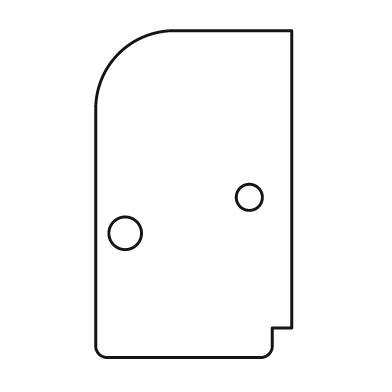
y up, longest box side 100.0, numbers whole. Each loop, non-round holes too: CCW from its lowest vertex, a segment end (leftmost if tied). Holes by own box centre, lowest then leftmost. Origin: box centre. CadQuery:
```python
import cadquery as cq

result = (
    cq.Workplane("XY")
    .moveTo(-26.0, -50.0)
    .lineTo(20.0, -50.0)
    .threePointArc((23.0, -49.0), (24.0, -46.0))
    .lineTo(24.0, -41.0)
    .lineTo(30.0, -41.0)
    .lineTo(30.0, 50.0)
    .lineTo(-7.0, 50.0)
    .threePointArc((-23.0, 43.0), (-30.0, 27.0))
    .lineTo(-30.0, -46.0)
    .threePointArc((-29.0, -49.0), (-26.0, -50.0))
    .close()
    .moveTo(-21.0, -12.0)
    .circle(5.0)
    .moveTo(17.0, -1.0)
    .circle(4.0)
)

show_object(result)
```